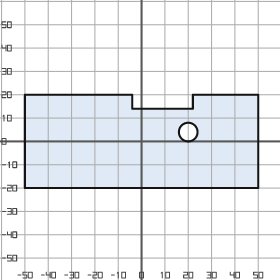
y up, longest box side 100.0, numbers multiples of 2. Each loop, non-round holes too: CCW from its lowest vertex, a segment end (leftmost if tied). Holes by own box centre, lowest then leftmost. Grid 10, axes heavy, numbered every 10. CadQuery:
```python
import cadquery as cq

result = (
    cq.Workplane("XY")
    .moveTo(-50.0, -20.0)
    .lineTo(50.0, -20.0)
    .lineTo(50.0, 20.0)
    .lineTo(22.0, 20.0)
    .lineTo(22.0, 14.0)
    .lineTo(-4.0, 14.0)
    .lineTo(-4.0, 20.0)
    .lineTo(-50.0, 20.0)
    .close()
    .moveTo(20.0, 4.0)
    .circle(4.0)
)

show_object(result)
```